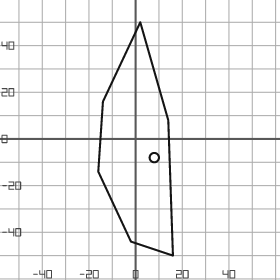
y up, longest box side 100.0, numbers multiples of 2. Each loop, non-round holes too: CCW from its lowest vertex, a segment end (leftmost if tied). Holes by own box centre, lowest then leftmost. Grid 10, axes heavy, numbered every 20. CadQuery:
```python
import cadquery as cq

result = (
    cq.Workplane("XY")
    .moveTo(16.0, -50.0)
    .lineTo(14.0, 8.0)
    .lineTo(2.0, 50.0)
    .lineTo(-14.0, 16.0)
    .lineTo(-16.0, -14.0)
    .lineTo(-2.0, -44.0)
    .close()
    .moveTo(8.0, -8.0)
    .circle(2.0)
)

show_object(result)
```